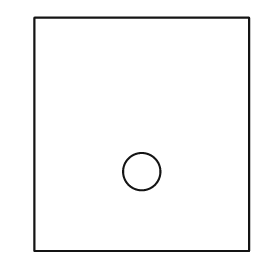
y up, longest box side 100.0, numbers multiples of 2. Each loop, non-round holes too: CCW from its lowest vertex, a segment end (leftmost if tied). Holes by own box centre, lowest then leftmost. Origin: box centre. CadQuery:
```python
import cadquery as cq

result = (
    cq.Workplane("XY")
    .moveTo(-46.0, -50.0)
    .lineTo(46.0, -50.0)
    .lineTo(46.0, 50.0)
    .lineTo(-46.0, 50.0)
    .close()
    .moveTo(0.0, -16.0)
    .circle(8.0)
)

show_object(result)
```